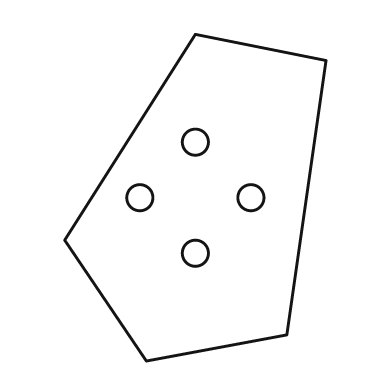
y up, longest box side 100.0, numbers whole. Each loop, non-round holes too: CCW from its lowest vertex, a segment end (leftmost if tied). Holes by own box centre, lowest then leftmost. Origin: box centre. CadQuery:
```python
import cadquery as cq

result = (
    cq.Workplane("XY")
    .moveTo(-15.0, -50.0)
    .lineTo(28.0, -42.0)
    .lineTo(40.0, 42.0)
    .lineTo(0.0, 50.0)
    .lineTo(-40.0, -13.0)
    .close()
    .moveTo(0.0, -17.0)
    .circle(4.0)
    .moveTo(-17.0, 0.0)
    .circle(4.0)
    .moveTo(17.0, 0.0)
    .circle(4.0)
    .moveTo(0.0, 17.0)
    .circle(4.0)
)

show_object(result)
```